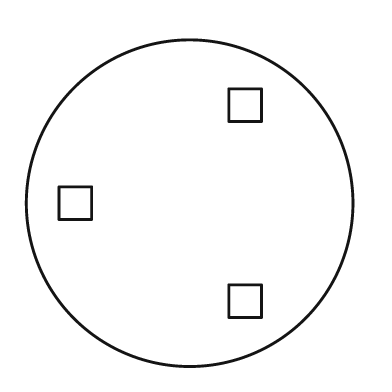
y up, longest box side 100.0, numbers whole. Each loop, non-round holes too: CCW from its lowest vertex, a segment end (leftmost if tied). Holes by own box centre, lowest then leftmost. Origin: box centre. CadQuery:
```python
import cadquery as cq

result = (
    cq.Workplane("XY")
    .moveTo(0.0, 0.0)
    .circle(50.0)
    .moveTo(12.0, -35.0)
    .lineTo(22.0, -35.0)
    .lineTo(22.0, -25.0)
    .lineTo(12.0, -25.0)
    .close()
    .moveTo(-40.0, -5.0)
    .lineTo(-30.0, -5.0)
    .lineTo(-30.0, 5.0)
    .lineTo(-40.0, 5.0)
    .close()
    .moveTo(12.0, 25.0)
    .lineTo(22.0, 25.0)
    .lineTo(22.0, 35.0)
    .lineTo(12.0, 35.0)
    .close()
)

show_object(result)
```